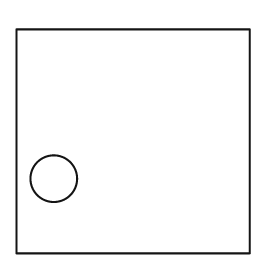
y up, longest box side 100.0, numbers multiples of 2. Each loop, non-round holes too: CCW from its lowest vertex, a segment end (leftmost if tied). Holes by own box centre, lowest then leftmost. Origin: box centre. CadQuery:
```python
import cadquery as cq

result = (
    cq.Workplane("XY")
    .moveTo(-50.0, -48.0)
    .lineTo(50.0, -48.0)
    .lineTo(50.0, 48.0)
    .lineTo(-50.0, 48.0)
    .close()
    .moveTo(-34.0, -16.0)
    .circle(10.0)
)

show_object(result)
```